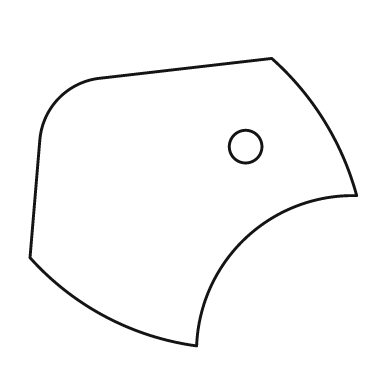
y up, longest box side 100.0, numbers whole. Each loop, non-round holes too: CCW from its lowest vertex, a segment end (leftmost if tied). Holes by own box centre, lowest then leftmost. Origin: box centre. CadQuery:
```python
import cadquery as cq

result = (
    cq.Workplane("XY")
    .moveTo(1.0, -44.0)
    .threePointArc((16.0, -11.0), (50.0, 2.0))
    .threePointArc((40.0, 25.0), (24.0, 44.0))
    .lineTo(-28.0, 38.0)
    .threePointArc((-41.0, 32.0), (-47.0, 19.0))
    .lineTo(-50.0, -17.0)
    .threePointArc((-27.0, -35.0), (1.0, -44.0))
    .close()
    .moveTo(16.0, 17.0)
    .circle(5.0)
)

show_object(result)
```